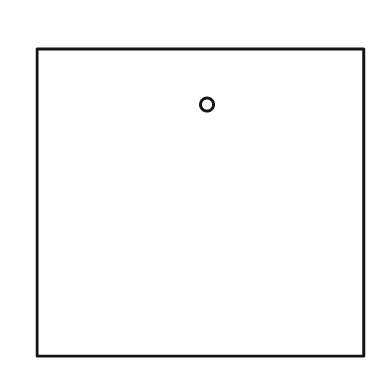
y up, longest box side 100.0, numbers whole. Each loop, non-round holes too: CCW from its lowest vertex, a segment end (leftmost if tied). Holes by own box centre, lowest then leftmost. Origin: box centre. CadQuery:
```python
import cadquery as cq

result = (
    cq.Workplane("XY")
    .moveTo(-50.0, -47.0)
    .lineTo(50.0, -47.0)
    .lineTo(50.0, 47.0)
    .lineTo(-50.0, 47.0)
    .close()
    .moveTo(2.0, 30.0)
    .circle(2.0)
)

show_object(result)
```